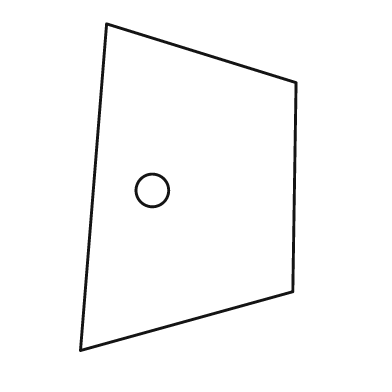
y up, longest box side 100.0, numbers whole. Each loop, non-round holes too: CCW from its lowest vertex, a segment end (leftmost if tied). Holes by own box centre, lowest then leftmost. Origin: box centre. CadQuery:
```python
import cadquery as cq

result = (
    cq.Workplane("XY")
    .moveTo(-33.0, -50.0)
    .lineTo(32.0, -32.0)
    .lineTo(33.0, 32.0)
    .lineTo(-25.0, 50.0)
    .close()
    .moveTo(-11.0, -1.0)
    .circle(5.0)
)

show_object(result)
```